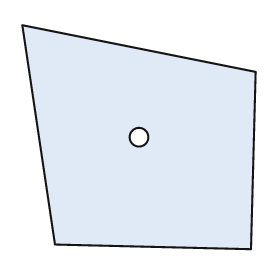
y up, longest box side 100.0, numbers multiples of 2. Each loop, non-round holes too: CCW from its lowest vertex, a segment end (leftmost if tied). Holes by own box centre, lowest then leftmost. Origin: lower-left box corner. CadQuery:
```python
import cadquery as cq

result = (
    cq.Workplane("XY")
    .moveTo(98.0, 0.0)
    .lineTo(100.0, 76.0)
    .lineTo(0.0, 96.0)
    .lineTo(14.0, 2.0)
    .close()
    .moveTo(50.0, 48.0)
    .circle(4.0)
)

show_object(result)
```